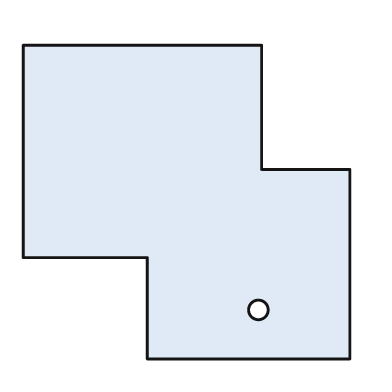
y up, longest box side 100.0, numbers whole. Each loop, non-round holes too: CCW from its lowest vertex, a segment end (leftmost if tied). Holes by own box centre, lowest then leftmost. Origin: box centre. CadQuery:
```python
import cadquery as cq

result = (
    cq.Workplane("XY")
    .moveTo(-12.0, -48.0)
    .lineTo(50.0, -48.0)
    .lineTo(50.0, 10.0)
    .lineTo(23.0, 10.0)
    .lineTo(23.0, 48.0)
    .lineTo(-50.0, 48.0)
    .lineTo(-50.0, -17.0)
    .lineTo(-12.0, -17.0)
    .close()
    .moveTo(22.0, -33.0)
    .circle(3.0)
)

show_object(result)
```